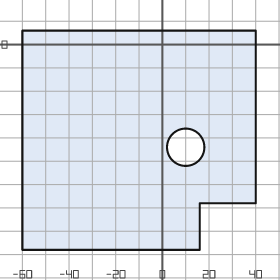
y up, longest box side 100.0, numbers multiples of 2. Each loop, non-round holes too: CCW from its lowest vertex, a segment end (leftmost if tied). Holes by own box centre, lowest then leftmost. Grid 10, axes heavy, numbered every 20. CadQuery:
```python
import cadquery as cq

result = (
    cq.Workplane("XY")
    .moveTo(-60.0, -88.0)
    .lineTo(16.0, -88.0)
    .lineTo(16.0, -68.0)
    .lineTo(40.0, -68.0)
    .lineTo(40.0, 6.0)
    .lineTo(-60.0, 6.0)
    .close()
    .moveTo(10.0, -44.0)
    .circle(8.0)
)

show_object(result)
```